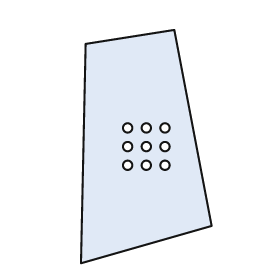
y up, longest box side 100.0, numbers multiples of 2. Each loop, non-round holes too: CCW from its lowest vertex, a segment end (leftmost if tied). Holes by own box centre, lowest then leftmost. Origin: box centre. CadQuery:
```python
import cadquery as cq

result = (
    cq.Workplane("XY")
    .moveTo(-28.0, -50.0)
    .lineTo(28.0, -34.0)
    .lineTo(12.0, 50.0)
    .lineTo(-26.0, 44.0)
    .close()
    .moveTo(-8.0, -8.0)
    .circle(2.0)
    .moveTo(0.0, -8.0)
    .circle(2.0)
    .moveTo(8.0, -8.0)
    .circle(2.0)
    .moveTo(-8.0, 0.0)
    .circle(2.0)
    .moveTo(0.0, 0.0)
    .circle(2.0)
    .moveTo(8.0, 0.0)
    .circle(2.0)
    .moveTo(-8.0, 8.0)
    .circle(2.0)
    .moveTo(0.0, 8.0)
    .circle(2.0)
    .moveTo(8.0, 8.0)
    .circle(2.0)
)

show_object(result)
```